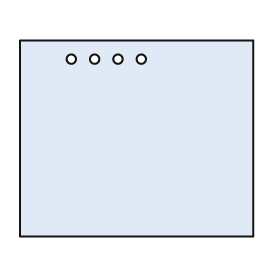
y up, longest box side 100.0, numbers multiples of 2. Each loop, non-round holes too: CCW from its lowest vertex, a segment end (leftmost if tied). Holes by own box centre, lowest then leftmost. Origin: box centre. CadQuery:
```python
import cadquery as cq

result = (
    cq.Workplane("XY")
    .moveTo(-50.0, -42.0)
    .lineTo(50.0, -42.0)
    .lineTo(50.0, 42.0)
    .lineTo(-50.0, 42.0)
    .close()
    .moveTo(-28.0, 34.0)
    .circle(2.0)
    .moveTo(-18.0, 34.0)
    .circle(2.0)
    .moveTo(-8.0, 34.0)
    .circle(2.0)
    .moveTo(2.0, 34.0)
    .circle(2.0)
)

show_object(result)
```